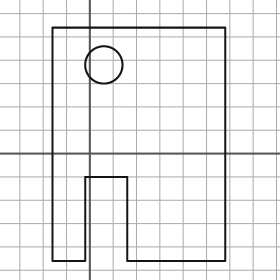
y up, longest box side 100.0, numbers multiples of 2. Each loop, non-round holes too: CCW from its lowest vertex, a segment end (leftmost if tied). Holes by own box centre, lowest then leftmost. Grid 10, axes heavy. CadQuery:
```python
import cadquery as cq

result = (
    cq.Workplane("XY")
    .moveTo(-16.0, -46.0)
    .lineTo(-2.0, -46.0)
    .lineTo(-2.0, -10.0)
    .lineTo(16.0, -10.0)
    .lineTo(16.0, -46.0)
    .lineTo(58.0, -46.0)
    .lineTo(58.0, 54.0)
    .lineTo(-16.0, 54.0)
    .close()
    .moveTo(6.0, 38.0)
    .circle(8.0)
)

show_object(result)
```